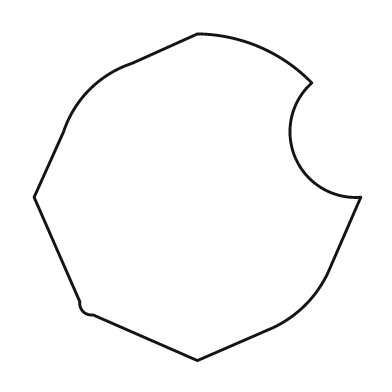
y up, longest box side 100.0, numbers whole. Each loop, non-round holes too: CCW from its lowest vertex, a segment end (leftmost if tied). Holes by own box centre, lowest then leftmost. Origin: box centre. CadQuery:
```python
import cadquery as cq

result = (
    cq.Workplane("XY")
    .moveTo(0.0, -50.0)
    .lineTo(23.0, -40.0)
    .threePointArc((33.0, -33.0), (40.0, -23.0))
    .lineTo(50.0, 0.0)
    .threePointArc((30.0, 12.0), (35.0, 35.0))
    .threePointArc((19.0, 46.0), (0.0, 50.0))
    .lineTo(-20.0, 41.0)
    .threePointArc((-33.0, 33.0), (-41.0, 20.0))
    .lineTo(-50.0, 0.0)
    .lineTo(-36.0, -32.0)
    .threePointArc((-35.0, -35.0), (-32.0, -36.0))
    .close()
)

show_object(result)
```